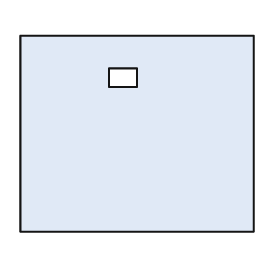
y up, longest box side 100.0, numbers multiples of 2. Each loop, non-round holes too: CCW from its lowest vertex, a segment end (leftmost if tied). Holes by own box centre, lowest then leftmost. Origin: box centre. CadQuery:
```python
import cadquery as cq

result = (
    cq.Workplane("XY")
    .moveTo(-50.0, -42.0)
    .lineTo(50.0, -42.0)
    .lineTo(50.0, 42.0)
    .lineTo(-50.0, 42.0)
    .close()
    .moveTo(-12.0, 20.0)
    .lineTo(0.0, 20.0)
    .lineTo(0.0, 28.0)
    .lineTo(-12.0, 28.0)
    .close()
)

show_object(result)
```